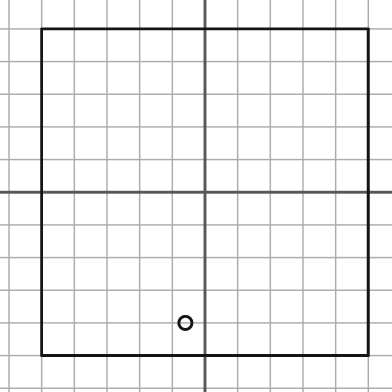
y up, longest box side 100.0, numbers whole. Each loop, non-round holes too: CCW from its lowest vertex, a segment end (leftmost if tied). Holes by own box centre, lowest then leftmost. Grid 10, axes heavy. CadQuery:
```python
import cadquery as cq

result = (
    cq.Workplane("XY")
    .moveTo(-50.0, -50.0)
    .lineTo(50.0, -50.0)
    .lineTo(50.0, 50.0)
    .lineTo(-50.0, 50.0)
    .close()
    .moveTo(-6.0, -40.0)
    .circle(2.0)
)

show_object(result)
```